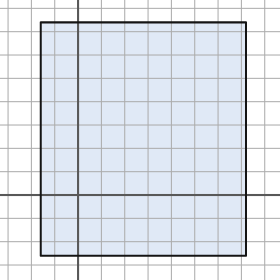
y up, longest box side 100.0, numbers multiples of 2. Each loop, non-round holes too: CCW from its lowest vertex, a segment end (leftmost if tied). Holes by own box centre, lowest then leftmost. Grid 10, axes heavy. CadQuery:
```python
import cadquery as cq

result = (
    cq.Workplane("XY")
    .moveTo(-16.0, -26.0)
    .lineTo(72.0, -26.0)
    .lineTo(72.0, 74.0)
    .lineTo(-16.0, 74.0)
    .close()
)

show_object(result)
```